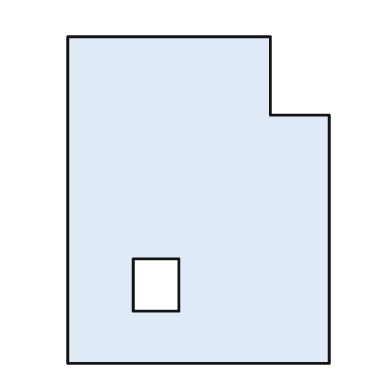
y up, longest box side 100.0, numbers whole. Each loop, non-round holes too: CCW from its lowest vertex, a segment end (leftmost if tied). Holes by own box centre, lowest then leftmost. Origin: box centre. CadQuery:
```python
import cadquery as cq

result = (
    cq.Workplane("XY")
    .moveTo(-40.0, -50.0)
    .lineTo(40.0, -50.0)
    .lineTo(40.0, 26.0)
    .lineTo(22.0, 26.0)
    .lineTo(22.0, 50.0)
    .lineTo(-40.0, 50.0)
    .close()
    .moveTo(-20.0, -34.0)
    .lineTo(-6.0, -34.0)
    .lineTo(-6.0, -18.0)
    .lineTo(-20.0, -18.0)
    .close()
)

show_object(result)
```